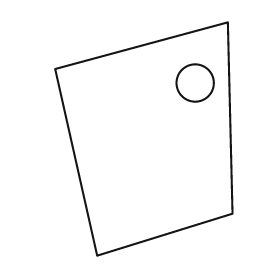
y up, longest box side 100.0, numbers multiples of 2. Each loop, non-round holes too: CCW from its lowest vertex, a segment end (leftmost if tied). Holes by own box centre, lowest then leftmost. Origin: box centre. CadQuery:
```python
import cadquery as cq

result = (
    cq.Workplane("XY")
    .moveTo(-20.0, -50.0)
    .lineTo(38.0, -32.0)
    .lineTo(36.0, 50.0)
    .lineTo(-38.0, 30.0)
    .close()
    .moveTo(22.0, 24.0)
    .circle(8.0)
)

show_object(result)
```